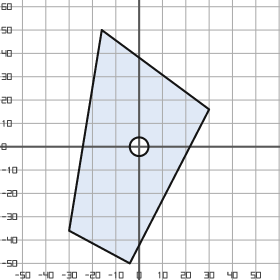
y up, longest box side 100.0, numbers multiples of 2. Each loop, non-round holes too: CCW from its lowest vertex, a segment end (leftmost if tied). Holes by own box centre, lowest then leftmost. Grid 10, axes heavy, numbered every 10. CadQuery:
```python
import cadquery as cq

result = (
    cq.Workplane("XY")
    .moveTo(-4.0, -50.0)
    .lineTo(30.0, 16.0)
    .lineTo(-16.0, 50.0)
    .lineTo(-30.0, -36.0)
    .close()
    .moveTo(0.0, 0.0)
    .circle(4.0)
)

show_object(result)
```